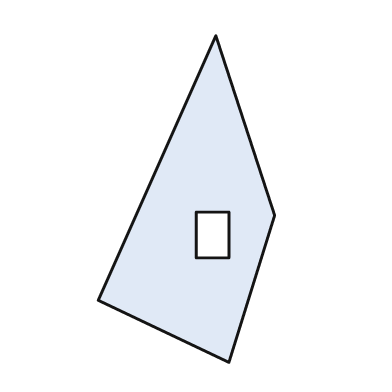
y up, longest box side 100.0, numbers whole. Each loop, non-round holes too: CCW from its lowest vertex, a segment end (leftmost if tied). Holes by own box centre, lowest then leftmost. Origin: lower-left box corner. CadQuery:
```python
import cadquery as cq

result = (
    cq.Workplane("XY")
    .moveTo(40.0, 0.0)
    .lineTo(54.0, 45.0)
    .lineTo(36.0, 100.0)
    .lineTo(0.0, 19.0)
    .close()
    .moveTo(30.0, 32.0)
    .lineTo(40.0, 32.0)
    .lineTo(40.0, 46.0)
    .lineTo(30.0, 46.0)
    .close()
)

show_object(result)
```